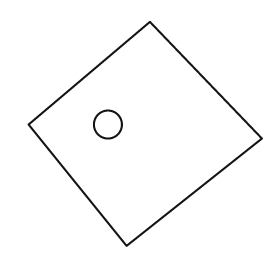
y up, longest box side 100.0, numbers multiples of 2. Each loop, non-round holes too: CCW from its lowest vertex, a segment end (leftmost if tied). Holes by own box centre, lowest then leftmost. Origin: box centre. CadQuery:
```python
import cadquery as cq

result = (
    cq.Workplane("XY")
    .moveTo(-8.0, -48.0)
    .lineTo(50.0, -2.0)
    .lineTo(2.0, 48.0)
    .lineTo(-50.0, 4.0)
    .close()
    .moveTo(-16.0, 4.0)
    .circle(6.0)
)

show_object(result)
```